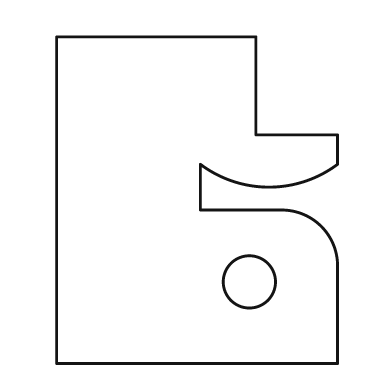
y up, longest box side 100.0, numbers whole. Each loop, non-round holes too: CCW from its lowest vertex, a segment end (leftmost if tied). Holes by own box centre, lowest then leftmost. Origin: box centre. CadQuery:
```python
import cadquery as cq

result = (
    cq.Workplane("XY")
    .moveTo(-43.0, -50.0)
    .lineTo(43.0, -50.0)
    .lineTo(43.0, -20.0)
    .threePointArc((38.0, -8.0), (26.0, -3.0))
    .lineTo(1.0, -3.0)
    .lineTo(1.0, 11.0)
    .threePointArc((22.0, 4.0), (43.0, 11.0))
    .lineTo(43.0, 20.0)
    .lineTo(18.0, 20.0)
    .lineTo(18.0, 50.0)
    .lineTo(-43.0, 50.0)
    .close()
    .moveTo(16.0, -25.0)
    .circle(8.0)
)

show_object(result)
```